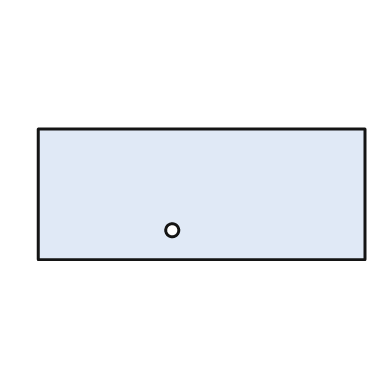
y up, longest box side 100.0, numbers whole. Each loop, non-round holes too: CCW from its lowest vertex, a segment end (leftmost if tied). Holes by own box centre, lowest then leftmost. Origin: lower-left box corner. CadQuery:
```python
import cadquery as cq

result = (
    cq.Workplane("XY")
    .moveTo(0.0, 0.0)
    .lineTo(100.0, 0.0)
    .lineTo(100.0, 40.0)
    .lineTo(0.0, 40.0)
    .close()
    .moveTo(41.0, 9.0)
    .circle(2.0)
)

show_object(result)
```